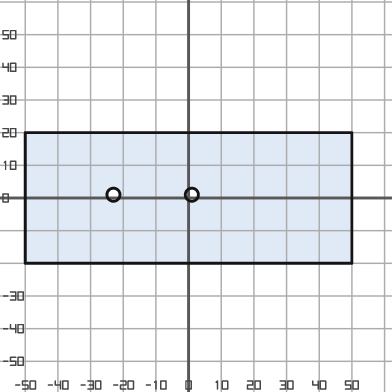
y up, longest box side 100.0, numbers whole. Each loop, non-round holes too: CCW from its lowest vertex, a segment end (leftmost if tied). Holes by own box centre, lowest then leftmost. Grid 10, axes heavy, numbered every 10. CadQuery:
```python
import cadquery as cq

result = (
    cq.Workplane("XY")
    .moveTo(-50.0, -20.0)
    .lineTo(50.0, -20.0)
    .lineTo(50.0, 20.0)
    .lineTo(-50.0, 20.0)
    .close()
    .moveTo(-23.0, 1.0)
    .circle(2.0)
    .moveTo(1.0, 1.0)
    .circle(2.0)
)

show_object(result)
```